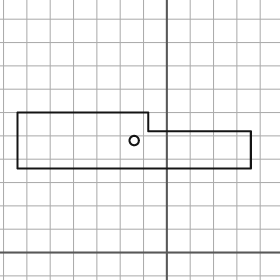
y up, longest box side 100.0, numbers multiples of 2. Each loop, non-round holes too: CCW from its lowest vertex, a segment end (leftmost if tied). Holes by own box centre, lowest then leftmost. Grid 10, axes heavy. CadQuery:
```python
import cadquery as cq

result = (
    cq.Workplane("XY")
    .moveTo(-64.0, 36.0)
    .lineTo(36.0, 36.0)
    .lineTo(36.0, 52.0)
    .lineTo(-8.0, 52.0)
    .lineTo(-8.0, 60.0)
    .lineTo(-64.0, 60.0)
    .close()
    .moveTo(-14.0, 48.0)
    .circle(2.0)
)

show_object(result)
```